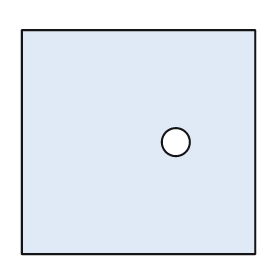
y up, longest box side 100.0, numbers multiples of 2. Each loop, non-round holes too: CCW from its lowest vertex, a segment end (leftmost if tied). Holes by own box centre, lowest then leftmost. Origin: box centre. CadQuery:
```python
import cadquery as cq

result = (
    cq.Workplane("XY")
    .moveTo(-50.0, -48.0)
    .lineTo(50.0, -48.0)
    .lineTo(50.0, 48.0)
    .lineTo(-50.0, 48.0)
    .close()
    .moveTo(16.0, 0.0)
    .circle(6.0)
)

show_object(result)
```